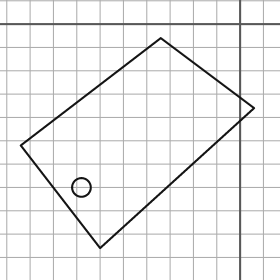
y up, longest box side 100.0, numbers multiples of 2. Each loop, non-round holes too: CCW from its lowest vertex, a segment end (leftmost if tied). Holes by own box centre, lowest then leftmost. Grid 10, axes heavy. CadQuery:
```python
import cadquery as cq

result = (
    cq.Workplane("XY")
    .moveTo(-60.0, -96.0)
    .lineTo(6.0, -36.0)
    .lineTo(-34.0, -6.0)
    .lineTo(-94.0, -52.0)
    .close()
    .moveTo(-68.0, -70.0)
    .circle(4.0)
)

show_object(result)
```